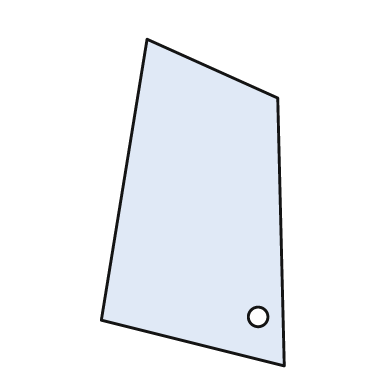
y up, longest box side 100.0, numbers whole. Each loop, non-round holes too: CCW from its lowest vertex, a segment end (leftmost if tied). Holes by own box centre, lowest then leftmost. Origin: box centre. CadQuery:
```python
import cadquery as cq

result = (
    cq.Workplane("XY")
    .moveTo(28.0, -50.0)
    .lineTo(26.0, 32.0)
    .lineTo(-14.0, 50.0)
    .lineTo(-28.0, -36.0)
    .close()
    .moveTo(20.0, -35.0)
    .circle(3.0)
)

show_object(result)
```